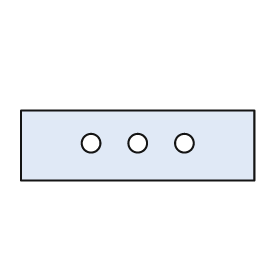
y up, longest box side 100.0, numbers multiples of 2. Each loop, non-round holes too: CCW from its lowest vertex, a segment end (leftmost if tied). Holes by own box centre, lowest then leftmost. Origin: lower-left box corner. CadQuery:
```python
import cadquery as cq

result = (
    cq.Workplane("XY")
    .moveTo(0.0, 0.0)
    .lineTo(100.0, 0.0)
    .lineTo(100.0, 30.0)
    .lineTo(0.0, 30.0)
    .close()
    .moveTo(30.0, 16.0)
    .circle(4.0)
    .moveTo(50.0, 16.0)
    .circle(4.0)
    .moveTo(70.0, 16.0)
    .circle(4.0)
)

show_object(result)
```